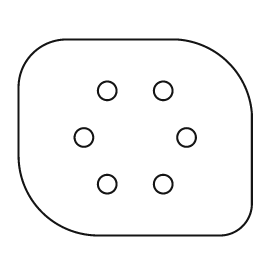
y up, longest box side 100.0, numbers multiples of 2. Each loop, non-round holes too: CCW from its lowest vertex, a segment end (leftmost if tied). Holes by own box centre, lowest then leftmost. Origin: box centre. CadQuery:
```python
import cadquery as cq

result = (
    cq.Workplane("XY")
    .moveTo(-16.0, -42.0)
    .lineTo(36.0, -42.0)
    .threePointArc((46.0, -38.0), (50.0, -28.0))
    .lineTo(50.0, 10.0)
    .threePointArc((40.0, 32.0), (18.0, 42.0))
    .lineTo(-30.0, 42.0)
    .threePointArc((-44.0, 36.0), (-50.0, 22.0))
    .lineTo(-50.0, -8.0)
    .threePointArc((-40.0, -32.0), (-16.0, -42.0))
    .close()
    .moveTo(-12.0, -20.0)
    .circle(4.0)
    .moveTo(12.0, -20.0)
    .circle(4.0)
    .moveTo(-22.0, 0.0)
    .circle(4.0)
    .moveTo(22.0, 0.0)
    .circle(4.0)
    .moveTo(-12.0, 20.0)
    .circle(4.0)
    .moveTo(12.0, 20.0)
    .circle(4.0)
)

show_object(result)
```